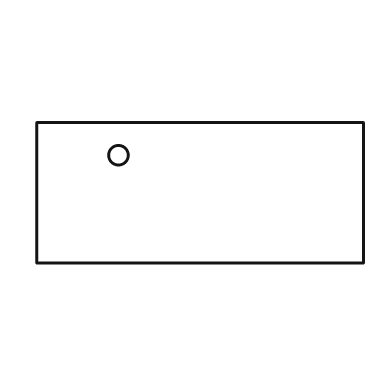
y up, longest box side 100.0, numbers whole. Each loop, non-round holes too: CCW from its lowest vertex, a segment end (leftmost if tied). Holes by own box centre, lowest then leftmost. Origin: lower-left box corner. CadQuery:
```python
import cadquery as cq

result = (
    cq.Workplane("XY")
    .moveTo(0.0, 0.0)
    .lineTo(100.0, 0.0)
    .lineTo(100.0, 43.0)
    .lineTo(0.0, 43.0)
    .close()
    .moveTo(25.0, 33.0)
    .circle(3.0)
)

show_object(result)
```